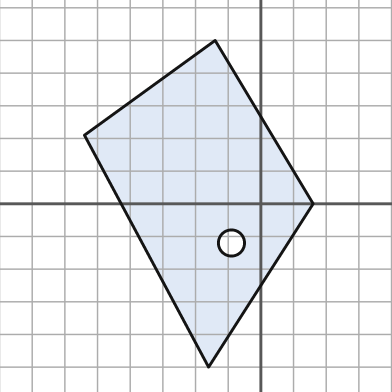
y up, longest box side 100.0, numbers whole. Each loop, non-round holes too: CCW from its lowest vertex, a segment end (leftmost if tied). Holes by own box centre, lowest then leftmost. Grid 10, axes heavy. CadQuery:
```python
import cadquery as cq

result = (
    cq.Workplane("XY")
    .moveTo(-16.0, -50.0)
    .lineTo(16.0, 0.0)
    .lineTo(-14.0, 50.0)
    .lineTo(-54.0, 21.0)
    .close()
    .moveTo(-9.0, -12.0)
    .circle(4.0)
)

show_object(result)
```